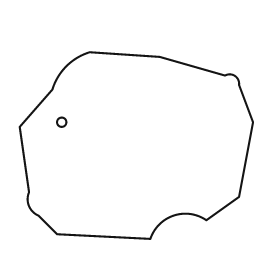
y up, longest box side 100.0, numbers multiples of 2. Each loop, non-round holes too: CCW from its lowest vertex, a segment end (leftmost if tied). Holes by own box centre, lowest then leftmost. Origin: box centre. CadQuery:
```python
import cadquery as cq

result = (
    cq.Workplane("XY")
    .moveTo(6.0, -40.0)
    .threePointArc((16.0, -30.0), (30.0, -32.0))
    .lineTo(44.0, -22.0)
    .lineTo(50.0, 10.0)
    .lineTo(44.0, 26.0)
    .threePointArc((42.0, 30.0), (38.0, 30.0))
    .lineTo(10.0, 38.0)
    .lineTo(-20.0, 40.0)
    .threePointArc((-30.0, 34.0), (-36.0, 24.0))
    .lineTo(-50.0, 8.0)
    .lineTo(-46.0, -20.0)
    .threePointArc((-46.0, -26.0), (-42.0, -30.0))
    .lineTo(-34.0, -38.0)
    .close()
    .moveTo(-32.0, 10.0)
    .circle(2.0)
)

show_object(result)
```